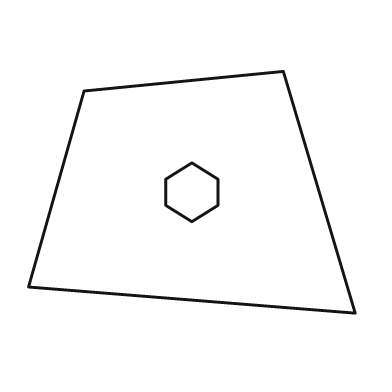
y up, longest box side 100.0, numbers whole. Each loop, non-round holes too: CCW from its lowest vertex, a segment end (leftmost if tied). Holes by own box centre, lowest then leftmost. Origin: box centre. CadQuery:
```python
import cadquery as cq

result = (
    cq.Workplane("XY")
    .moveTo(50.0, -37.0)
    .lineTo(28.0, 37.0)
    .lineTo(-33.0, 31.0)
    .lineTo(-50.0, -29.0)
    .close()
    .moveTo(0.0, -9.0)
    .lineTo(8.0, -4.0)
    .lineTo(8.0, 4.0)
    .lineTo(0.0, 9.0)
    .lineTo(-8.0, 4.0)
    .lineTo(-8.0, -4.0)
    .close()
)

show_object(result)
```